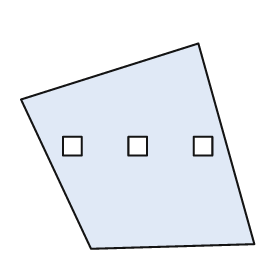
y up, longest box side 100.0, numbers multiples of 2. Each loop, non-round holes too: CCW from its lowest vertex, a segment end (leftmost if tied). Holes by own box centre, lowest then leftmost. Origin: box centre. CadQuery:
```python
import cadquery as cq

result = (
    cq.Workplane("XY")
    .moveTo(-20.0, -44.0)
    .lineTo(50.0, -42.0)
    .lineTo(26.0, 44.0)
    .lineTo(-50.0, 20.0)
    .close()
    .moveTo(-32.0, -4.0)
    .lineTo(-24.0, -4.0)
    .lineTo(-24.0, 4.0)
    .lineTo(-32.0, 4.0)
    .close()
    .moveTo(-4.0, -4.0)
    .lineTo(4.0, -4.0)
    .lineTo(4.0, 4.0)
    .lineTo(-4.0, 4.0)
    .close()
    .moveTo(24.0, -4.0)
    .lineTo(32.0, -4.0)
    .lineTo(32.0, 4.0)
    .lineTo(24.0, 4.0)
    .close()
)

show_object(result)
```